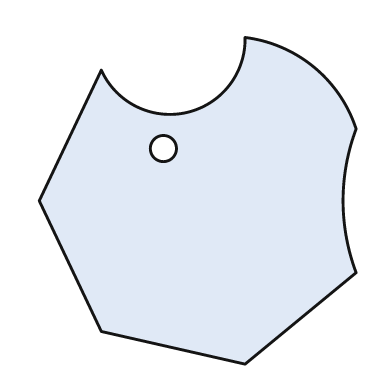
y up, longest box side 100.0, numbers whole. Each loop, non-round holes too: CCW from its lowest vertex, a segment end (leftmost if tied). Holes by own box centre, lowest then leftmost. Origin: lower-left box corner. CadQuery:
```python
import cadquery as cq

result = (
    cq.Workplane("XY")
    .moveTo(63.0, 0.0)
    .lineTo(97.0, 28.0)
    .threePointArc((93.0, 50.0), (97.0, 72.0))
    .threePointArc((84.0, 91.0), (63.0, 100.0))
    .threePointArc((45.0, 77.0), (19.0, 90.0))
    .lineTo(0.0, 50.0)
    .lineTo(19.0, 10.0)
    .close()
    .moveTo(38.0, 66.0)
    .circle(4.0)
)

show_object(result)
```